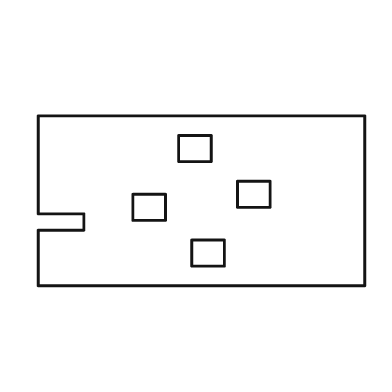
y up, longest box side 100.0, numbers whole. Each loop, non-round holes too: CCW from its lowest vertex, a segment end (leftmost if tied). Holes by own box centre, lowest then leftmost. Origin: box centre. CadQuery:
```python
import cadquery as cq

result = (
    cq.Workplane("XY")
    .moveTo(-50.0, -26.0)
    .lineTo(50.0, -26.0)
    .lineTo(50.0, 26.0)
    .lineTo(-50.0, 26.0)
    .lineTo(-50.0, -4.0)
    .lineTo(-36.0, -4.0)
    .lineTo(-36.0, -9.0)
    .lineTo(-50.0, -9.0)
    .close()
    .moveTo(-3.0, -20.0)
    .lineTo(7.0, -20.0)
    .lineTo(7.0, -12.0)
    .lineTo(-3.0, -12.0)
    .close()
    .moveTo(-21.0, -6.0)
    .lineTo(-11.0, -6.0)
    .lineTo(-11.0, 2.0)
    .lineTo(-21.0, 2.0)
    .close()
    .moveTo(11.0, -2.0)
    .lineTo(21.0, -2.0)
    .lineTo(21.0, 6.0)
    .lineTo(11.0, 6.0)
    .close()
    .moveTo(-7.0, 12.0)
    .lineTo(3.0, 12.0)
    .lineTo(3.0, 20.0)
    .lineTo(-7.0, 20.0)
    .close()
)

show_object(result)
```